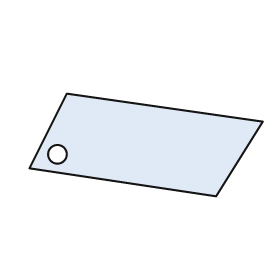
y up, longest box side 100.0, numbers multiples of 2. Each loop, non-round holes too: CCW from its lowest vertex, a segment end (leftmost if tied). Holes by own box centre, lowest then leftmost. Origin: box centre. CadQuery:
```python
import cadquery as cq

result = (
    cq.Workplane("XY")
    .moveTo(30.0, -22.0)
    .lineTo(50.0, 10.0)
    .lineTo(-34.0, 22.0)
    .lineTo(-50.0, -10.0)
    .close()
    .moveTo(-38.0, -4.0)
    .circle(4.0)
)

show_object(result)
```